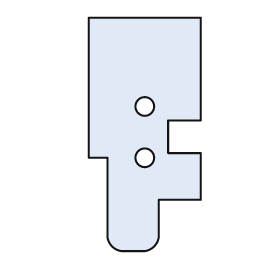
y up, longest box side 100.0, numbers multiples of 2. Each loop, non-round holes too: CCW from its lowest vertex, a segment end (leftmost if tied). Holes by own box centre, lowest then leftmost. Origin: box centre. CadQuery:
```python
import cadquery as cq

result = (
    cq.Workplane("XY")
    .moveTo(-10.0, -50.0)
    .lineTo(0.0, -50.0)
    .threePointArc((4.0, -48.0), (6.0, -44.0))
    .lineTo(6.0, -28.0)
    .lineTo(24.0, -28.0)
    .lineTo(24.0, -8.0)
    .lineTo(10.0, -8.0)
    .lineTo(10.0, 6.0)
    .lineTo(24.0, 6.0)
    .lineTo(24.0, 50.0)
    .lineTo(-24.0, 50.0)
    .lineTo(-24.0, -10.0)
    .lineTo(-16.0, -10.0)
    .lineTo(-16.0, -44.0)
    .threePointArc((-14.0, -48.0), (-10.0, -50.0))
    .close()
    .moveTo(0.0, -10.0)
    .circle(4.0)
    .moveTo(0.0, 12.0)
    .circle(4.0)
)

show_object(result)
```